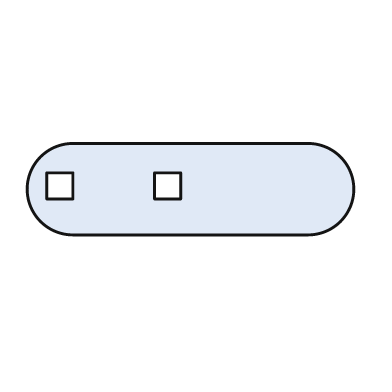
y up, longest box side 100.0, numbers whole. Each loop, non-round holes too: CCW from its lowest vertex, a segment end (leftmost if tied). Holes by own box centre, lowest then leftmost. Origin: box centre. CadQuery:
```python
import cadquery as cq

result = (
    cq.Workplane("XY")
    .moveTo(-36.0, -14.0)
    .lineTo(36.0, -14.0)
    .threePointArc((50.0, 0.0), (36.0, 14.0))
    .lineTo(-36.0, 14.0)
    .threePointArc((-50.0, 0.0), (-36.0, -14.0))
    .close()
    .moveTo(-44.0, -3.0)
    .lineTo(-36.0, -3.0)
    .lineTo(-36.0, 5.0)
    .lineTo(-44.0, 5.0)
    .close()
    .moveTo(-11.0, -3.0)
    .lineTo(-3.0, -3.0)
    .lineTo(-3.0, 5.0)
    .lineTo(-11.0, 5.0)
    .close()
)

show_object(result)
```